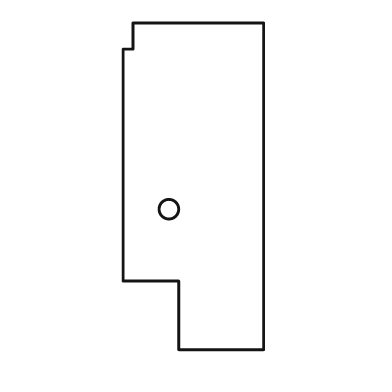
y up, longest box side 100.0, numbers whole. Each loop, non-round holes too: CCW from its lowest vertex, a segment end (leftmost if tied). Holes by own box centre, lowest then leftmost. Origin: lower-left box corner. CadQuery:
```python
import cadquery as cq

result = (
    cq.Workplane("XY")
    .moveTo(17.0, 0.0)
    .lineTo(43.0, 0.0)
    .lineTo(43.0, 100.0)
    .lineTo(3.0, 100.0)
    .lineTo(3.0, 92.0)
    .lineTo(0.0, 92.0)
    .lineTo(0.0, 21.0)
    .lineTo(17.0, 21.0)
    .close()
    .moveTo(14.0, 43.0)
    .circle(3.0)
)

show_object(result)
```